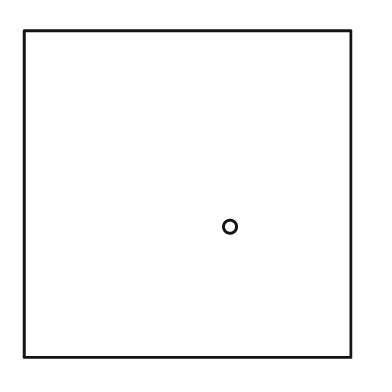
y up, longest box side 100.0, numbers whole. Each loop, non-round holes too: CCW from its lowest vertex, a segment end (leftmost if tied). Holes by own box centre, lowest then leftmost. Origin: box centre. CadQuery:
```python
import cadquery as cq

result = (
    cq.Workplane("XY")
    .moveTo(-50.0, -50.0)
    .lineTo(50.0, -50.0)
    .lineTo(50.0, 50.0)
    .lineTo(-50.0, 50.0)
    .close()
    .moveTo(13.0, -10.0)
    .circle(2.0)
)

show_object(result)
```